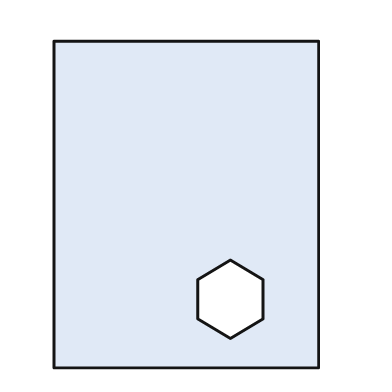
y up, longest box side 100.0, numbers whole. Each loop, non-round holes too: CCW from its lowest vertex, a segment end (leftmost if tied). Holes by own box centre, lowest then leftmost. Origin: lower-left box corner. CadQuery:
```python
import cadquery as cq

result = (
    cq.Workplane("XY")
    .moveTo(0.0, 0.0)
    .lineTo(81.0, 0.0)
    .lineTo(81.0, 100.0)
    .lineTo(0.0, 100.0)
    .close()
    .moveTo(54.0, 9.0)
    .lineTo(64.0, 15.0)
    .lineTo(64.0, 27.0)
    .lineTo(54.0, 33.0)
    .lineTo(44.0, 27.0)
    .lineTo(44.0, 15.0)
    .close()
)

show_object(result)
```